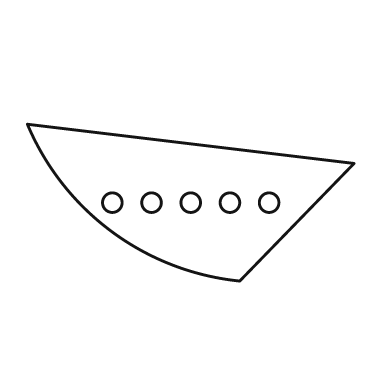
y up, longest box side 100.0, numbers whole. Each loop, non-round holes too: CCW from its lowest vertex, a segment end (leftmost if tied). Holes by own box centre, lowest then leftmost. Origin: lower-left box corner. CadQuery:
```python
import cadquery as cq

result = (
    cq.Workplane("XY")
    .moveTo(65.0, 0.0)
    .lineTo(100.0, 36.0)
    .lineTo(0.0, 48.0)
    .threePointArc((26.0, 15.0), (65.0, 0.0))
    .close()
    .moveTo(26.0, 24.0)
    .circle(3.0)
    .moveTo(38.0, 24.0)
    .circle(3.0)
    .moveTo(50.0, 24.0)
    .circle(3.0)
    .moveTo(62.0, 24.0)
    .circle(3.0)
    .moveTo(74.0, 24.0)
    .circle(3.0)
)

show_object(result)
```